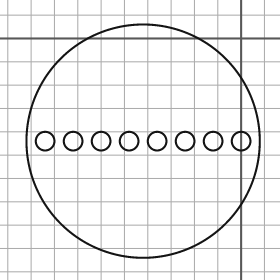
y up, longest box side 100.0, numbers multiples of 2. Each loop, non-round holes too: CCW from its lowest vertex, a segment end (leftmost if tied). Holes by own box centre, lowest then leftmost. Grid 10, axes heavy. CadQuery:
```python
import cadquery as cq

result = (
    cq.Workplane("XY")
    .moveTo(-42.0, -44.0)
    .circle(50.0)
    .moveTo(-84.0, -44.0)
    .circle(4.0)
    .moveTo(-72.0, -44.0)
    .circle(4.0)
    .moveTo(-60.0, -44.0)
    .circle(4.0)
    .moveTo(-48.0, -44.0)
    .circle(4.0)
    .moveTo(-36.0, -44.0)
    .circle(4.0)
    .moveTo(-24.0, -44.0)
    .circle(4.0)
    .moveTo(-12.0, -44.0)
    .circle(4.0)
    .moveTo(0.0, -44.0)
    .circle(4.0)
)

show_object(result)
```